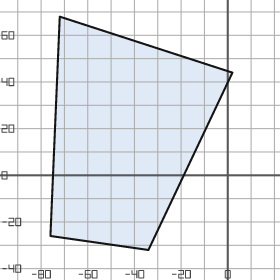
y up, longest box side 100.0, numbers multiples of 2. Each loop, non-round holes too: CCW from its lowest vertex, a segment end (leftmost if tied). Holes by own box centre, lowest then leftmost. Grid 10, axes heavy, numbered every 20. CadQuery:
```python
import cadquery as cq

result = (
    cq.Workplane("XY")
    .moveTo(-34.0, -32.0)
    .lineTo(2.0, 44.0)
    .lineTo(-72.0, 68.0)
    .lineTo(-76.0, -26.0)
    .close()
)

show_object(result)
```